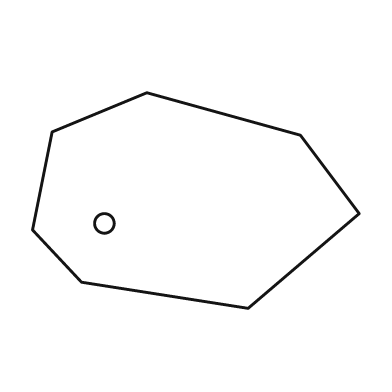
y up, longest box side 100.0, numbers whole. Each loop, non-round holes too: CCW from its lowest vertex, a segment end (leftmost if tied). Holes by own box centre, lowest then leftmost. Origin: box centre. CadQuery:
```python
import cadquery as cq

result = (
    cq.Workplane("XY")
    .moveTo(16.0, -33.0)
    .lineTo(50.0, -4.0)
    .lineTo(32.0, 20.0)
    .lineTo(-15.0, 33.0)
    .lineTo(-44.0, 21.0)
    .lineTo(-50.0, -9.0)
    .lineTo(-35.0, -25.0)
    .close()
    .moveTo(-28.0, -7.0)
    .circle(3.0)
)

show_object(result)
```